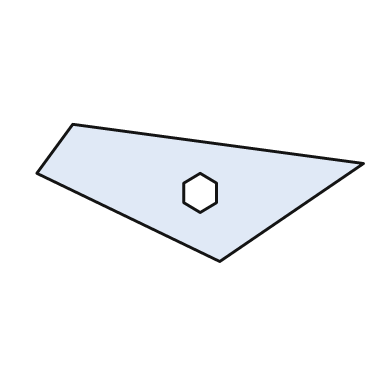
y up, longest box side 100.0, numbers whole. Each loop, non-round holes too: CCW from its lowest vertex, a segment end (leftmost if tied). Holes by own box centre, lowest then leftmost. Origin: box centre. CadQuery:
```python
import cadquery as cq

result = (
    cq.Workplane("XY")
    .moveTo(6.0, -21.0)
    .lineTo(50.0, 9.0)
    .lineTo(-39.0, 21.0)
    .lineTo(-50.0, 6.0)
    .close()
    .moveTo(0.0, -6.0)
    .lineTo(5.0, -3.0)
    .lineTo(5.0, 3.0)
    .lineTo(0.0, 6.0)
    .lineTo(-5.0, 3.0)
    .lineTo(-5.0, -3.0)
    .close()
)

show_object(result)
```